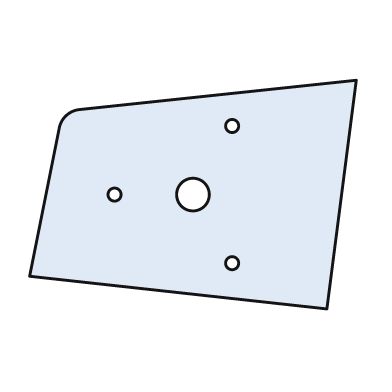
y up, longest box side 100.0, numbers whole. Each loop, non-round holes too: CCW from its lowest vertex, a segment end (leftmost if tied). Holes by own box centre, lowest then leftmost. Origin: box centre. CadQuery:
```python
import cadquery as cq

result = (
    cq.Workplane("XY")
    .moveTo(41.0, -35.0)
    .lineTo(50.0, 35.0)
    .lineTo(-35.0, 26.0)
    .threePointArc((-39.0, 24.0), (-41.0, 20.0))
    .lineTo(-50.0, -25.0)
    .close()
    .moveTo(12.0, -21.0)
    .circle(2.0)
    .moveTo(-24.0, 0.0)
    .circle(2.0)
    .moveTo(0.0, 0.0)
    .circle(5.0)
    .moveTo(12.0, 21.0)
    .circle(2.0)
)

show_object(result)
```